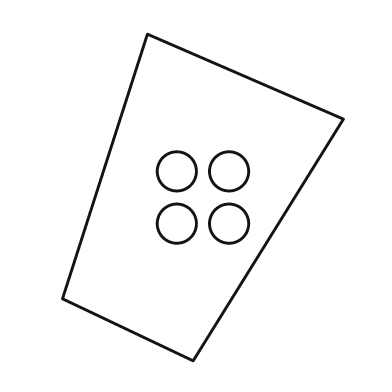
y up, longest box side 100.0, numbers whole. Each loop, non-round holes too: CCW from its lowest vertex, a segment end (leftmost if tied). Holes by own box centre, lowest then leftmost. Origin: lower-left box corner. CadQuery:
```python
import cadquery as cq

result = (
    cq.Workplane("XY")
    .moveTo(40.0, 0.0)
    .lineTo(86.0, 74.0)
    .lineTo(26.0, 100.0)
    .lineTo(0.0, 19.0)
    .close()
    .moveTo(35.0, 42.0)
    .circle(6.0)
    .moveTo(51.0, 42.0)
    .circle(6.0)
    .moveTo(35.0, 58.0)
    .circle(6.0)
    .moveTo(51.0, 58.0)
    .circle(6.0)
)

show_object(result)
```